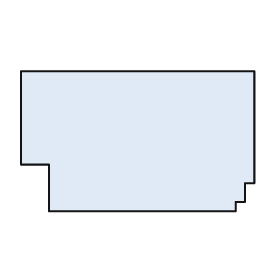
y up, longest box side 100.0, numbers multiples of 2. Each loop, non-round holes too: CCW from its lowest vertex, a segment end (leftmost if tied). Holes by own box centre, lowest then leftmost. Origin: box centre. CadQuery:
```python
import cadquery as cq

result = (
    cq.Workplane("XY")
    .moveTo(-38.0, -30.0)
    .lineTo(42.0, -30.0)
    .lineTo(42.0, -26.0)
    .lineTo(46.0, -26.0)
    .lineTo(46.0, -18.0)
    .lineTo(50.0, -18.0)
    .lineTo(50.0, 30.0)
    .lineTo(-50.0, 30.0)
    .lineTo(-50.0, -10.0)
    .lineTo(-38.0, -10.0)
    .close()
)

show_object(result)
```